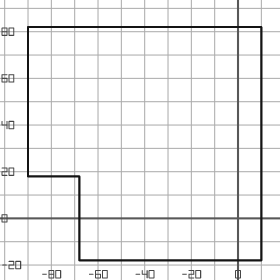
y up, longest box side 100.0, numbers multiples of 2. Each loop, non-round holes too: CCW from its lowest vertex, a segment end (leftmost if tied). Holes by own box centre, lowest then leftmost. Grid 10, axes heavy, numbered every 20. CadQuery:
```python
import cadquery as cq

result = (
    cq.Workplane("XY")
    .moveTo(-68.0, -18.0)
    .lineTo(10.0, -18.0)
    .lineTo(10.0, 82.0)
    .lineTo(-90.0, 82.0)
    .lineTo(-90.0, 18.0)
    .lineTo(-68.0, 18.0)
    .close()
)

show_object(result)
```